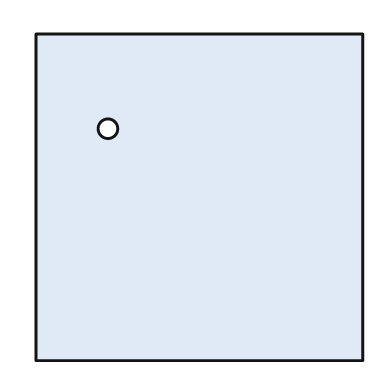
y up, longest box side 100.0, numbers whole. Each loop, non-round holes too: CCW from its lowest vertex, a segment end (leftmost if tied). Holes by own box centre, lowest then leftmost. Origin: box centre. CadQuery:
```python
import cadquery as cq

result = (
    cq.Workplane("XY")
    .moveTo(-50.0, -50.0)
    .lineTo(50.0, -50.0)
    .lineTo(50.0, 50.0)
    .lineTo(-50.0, 50.0)
    .close()
    .moveTo(-28.0, 21.0)
    .circle(3.0)
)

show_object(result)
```